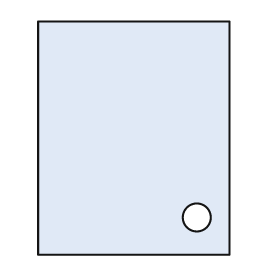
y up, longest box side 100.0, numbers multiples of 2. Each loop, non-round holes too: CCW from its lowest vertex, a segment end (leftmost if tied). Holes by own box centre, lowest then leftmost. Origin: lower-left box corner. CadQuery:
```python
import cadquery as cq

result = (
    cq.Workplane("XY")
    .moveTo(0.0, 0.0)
    .lineTo(82.0, 0.0)
    .lineTo(82.0, 100.0)
    .lineTo(0.0, 100.0)
    .close()
    .moveTo(68.0, 16.0)
    .circle(6.0)
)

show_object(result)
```